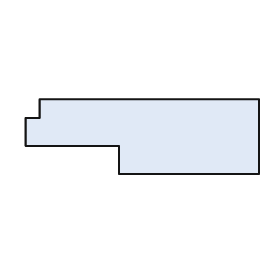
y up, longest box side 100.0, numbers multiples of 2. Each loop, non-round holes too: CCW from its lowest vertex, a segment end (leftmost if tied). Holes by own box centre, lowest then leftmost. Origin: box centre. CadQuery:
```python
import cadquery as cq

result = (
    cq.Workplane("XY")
    .moveTo(-10.0, -16.0)
    .lineTo(50.0, -16.0)
    .lineTo(50.0, 16.0)
    .lineTo(-44.0, 16.0)
    .lineTo(-44.0, 8.0)
    .lineTo(-50.0, 8.0)
    .lineTo(-50.0, -4.0)
    .lineTo(-10.0, -4.0)
    .close()
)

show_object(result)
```